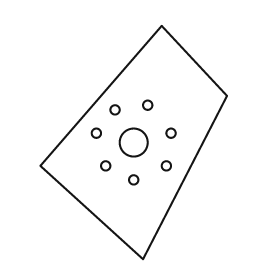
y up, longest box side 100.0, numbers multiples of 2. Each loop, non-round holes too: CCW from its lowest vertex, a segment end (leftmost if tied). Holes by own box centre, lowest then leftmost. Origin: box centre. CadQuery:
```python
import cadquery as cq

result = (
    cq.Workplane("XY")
    .moveTo(4.0, -50.0)
    .lineTo(40.0, 20.0)
    .lineTo(12.0, 50.0)
    .lineTo(-40.0, -10.0)
    .close()
    .moveTo(0.0, -16.0)
    .circle(2.0)
    .moveTo(-12.0, -10.0)
    .circle(2.0)
    .moveTo(14.0, -10.0)
    .circle(2.0)
    .moveTo(0.0, 0.0)
    .circle(6.0)
    .moveTo(-16.0, 4.0)
    .circle(2.0)
    .moveTo(16.0, 4.0)
    .circle(2.0)
    .moveTo(-8.0, 14.0)
    .circle(2.0)
    .moveTo(6.0, 16.0)
    .circle(2.0)
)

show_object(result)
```